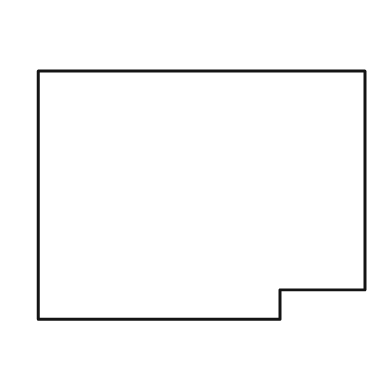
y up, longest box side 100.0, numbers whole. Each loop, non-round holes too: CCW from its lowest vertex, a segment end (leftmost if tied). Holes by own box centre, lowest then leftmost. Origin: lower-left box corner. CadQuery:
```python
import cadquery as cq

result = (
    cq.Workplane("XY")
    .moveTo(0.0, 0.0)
    .lineTo(74.0, 0.0)
    .lineTo(74.0, 9.0)
    .lineTo(100.0, 9.0)
    .lineTo(100.0, 76.0)
    .lineTo(0.0, 76.0)
    .close()
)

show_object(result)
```